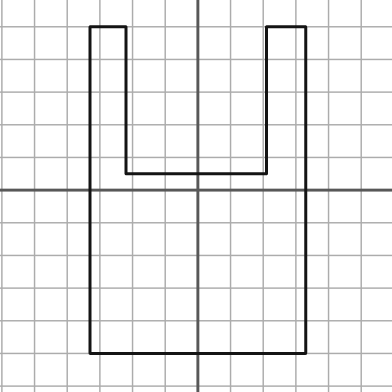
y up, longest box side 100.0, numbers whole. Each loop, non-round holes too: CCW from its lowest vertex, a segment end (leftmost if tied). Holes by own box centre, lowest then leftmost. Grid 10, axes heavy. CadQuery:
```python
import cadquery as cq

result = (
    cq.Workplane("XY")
    .moveTo(-33.0, -50.0)
    .lineTo(33.0, -50.0)
    .lineTo(33.0, 50.0)
    .lineTo(21.0, 50.0)
    .lineTo(21.0, 5.0)
    .lineTo(-22.0, 5.0)
    .lineTo(-22.0, 50.0)
    .lineTo(-33.0, 50.0)
    .close()
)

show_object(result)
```